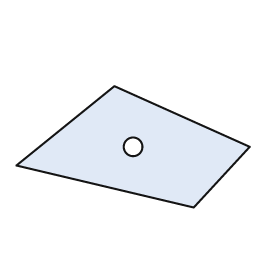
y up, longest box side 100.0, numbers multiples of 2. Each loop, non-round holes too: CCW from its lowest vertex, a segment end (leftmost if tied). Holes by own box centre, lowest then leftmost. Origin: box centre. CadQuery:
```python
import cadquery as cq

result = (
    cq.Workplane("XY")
    .moveTo(26.0, -26.0)
    .lineTo(50.0, 0.0)
    .lineTo(-8.0, 26.0)
    .lineTo(-50.0, -8.0)
    .close()
    .moveTo(0.0, 0.0)
    .circle(4.0)
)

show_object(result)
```